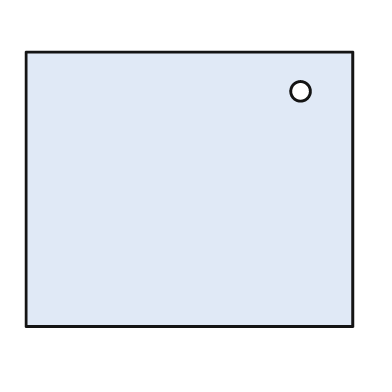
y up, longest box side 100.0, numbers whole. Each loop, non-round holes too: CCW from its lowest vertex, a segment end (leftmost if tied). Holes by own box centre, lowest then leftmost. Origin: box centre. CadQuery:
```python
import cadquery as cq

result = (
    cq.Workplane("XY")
    .moveTo(-50.0, -42.0)
    .lineTo(50.0, -42.0)
    .lineTo(50.0, 42.0)
    .lineTo(-50.0, 42.0)
    .close()
    .moveTo(34.0, 30.0)
    .circle(3.0)
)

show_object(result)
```